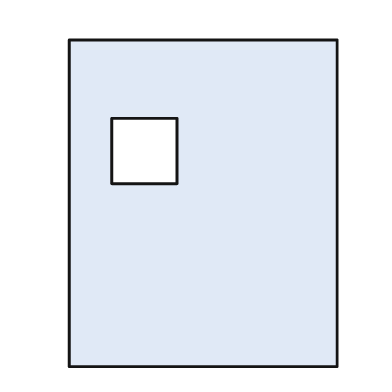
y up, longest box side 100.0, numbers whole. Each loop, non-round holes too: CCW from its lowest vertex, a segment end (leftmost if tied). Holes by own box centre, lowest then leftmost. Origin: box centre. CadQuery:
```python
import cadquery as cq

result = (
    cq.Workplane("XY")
    .moveTo(-41.0, -50.0)
    .lineTo(41.0, -50.0)
    .lineTo(41.0, 50.0)
    .lineTo(-41.0, 50.0)
    .close()
    .moveTo(-28.0, 6.0)
    .lineTo(-8.0, 6.0)
    .lineTo(-8.0, 26.0)
    .lineTo(-28.0, 26.0)
    .close()
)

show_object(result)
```